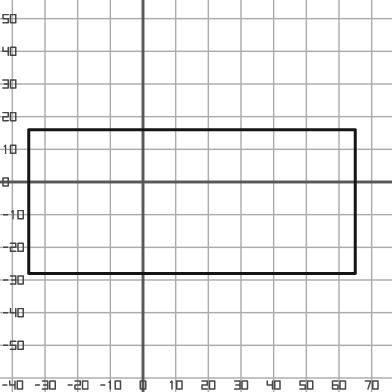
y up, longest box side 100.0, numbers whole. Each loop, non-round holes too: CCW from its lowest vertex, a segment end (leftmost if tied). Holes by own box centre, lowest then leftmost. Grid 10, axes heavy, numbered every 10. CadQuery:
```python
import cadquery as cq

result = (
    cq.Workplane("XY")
    .moveTo(-35.0, -28.0)
    .lineTo(65.0, -28.0)
    .lineTo(65.0, 16.0)
    .lineTo(-35.0, 16.0)
    .close()
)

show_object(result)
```